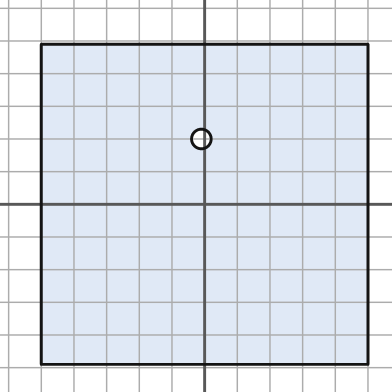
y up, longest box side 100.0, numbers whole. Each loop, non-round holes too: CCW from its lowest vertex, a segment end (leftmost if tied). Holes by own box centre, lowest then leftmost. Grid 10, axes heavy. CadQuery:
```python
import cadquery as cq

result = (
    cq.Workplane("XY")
    .moveTo(-50.0, -49.0)
    .lineTo(50.0, -49.0)
    .lineTo(50.0, 49.0)
    .lineTo(-50.0, 49.0)
    .close()
    .moveTo(-1.0, 20.0)
    .circle(3.0)
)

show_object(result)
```